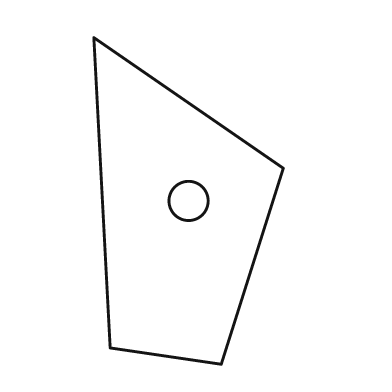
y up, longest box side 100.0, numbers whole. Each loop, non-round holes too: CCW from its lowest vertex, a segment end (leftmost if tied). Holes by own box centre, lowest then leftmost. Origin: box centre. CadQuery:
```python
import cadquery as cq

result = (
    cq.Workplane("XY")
    .moveTo(10.0, -50.0)
    .lineTo(29.0, 10.0)
    .lineTo(-29.0, 50.0)
    .lineTo(-24.0, -45.0)
    .close()
    .moveTo(0.0, 0.0)
    .circle(6.0)
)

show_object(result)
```